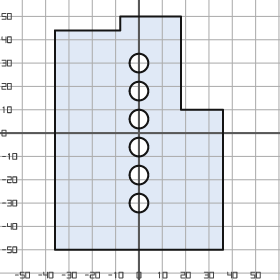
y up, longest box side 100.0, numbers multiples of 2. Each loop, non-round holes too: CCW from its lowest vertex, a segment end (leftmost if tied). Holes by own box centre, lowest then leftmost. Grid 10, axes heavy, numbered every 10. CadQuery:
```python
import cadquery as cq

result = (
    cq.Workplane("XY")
    .moveTo(-36.0, -50.0)
    .lineTo(36.0, -50.0)
    .lineTo(36.0, 10.0)
    .lineTo(18.0, 10.0)
    .lineTo(18.0, 50.0)
    .lineTo(-8.0, 50.0)
    .lineTo(-8.0, 44.0)
    .lineTo(-36.0, 44.0)
    .close()
    .moveTo(0.0, -30.0)
    .circle(4.0)
    .moveTo(0.0, -18.0)
    .circle(4.0)
    .moveTo(0.0, -6.0)
    .circle(4.0)
    .moveTo(0.0, 6.0)
    .circle(4.0)
    .moveTo(0.0, 18.0)
    .circle(4.0)
    .moveTo(0.0, 30.0)
    .circle(4.0)
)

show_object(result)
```